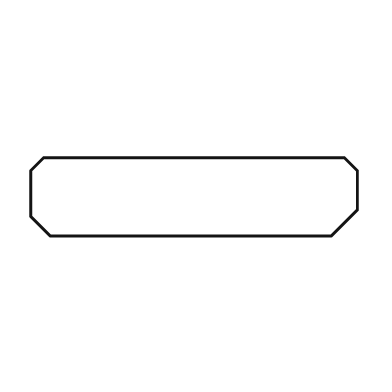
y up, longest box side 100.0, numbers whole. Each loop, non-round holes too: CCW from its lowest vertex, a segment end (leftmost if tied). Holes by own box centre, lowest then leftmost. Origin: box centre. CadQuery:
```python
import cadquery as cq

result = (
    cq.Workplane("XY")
    .moveTo(-44.0, -12.0)
    .lineTo(42.0, -12.0)
    .lineTo(50.0, -4.0)
    .lineTo(50.0, 8.0)
    .lineTo(46.0, 12.0)
    .lineTo(-46.0, 12.0)
    .lineTo(-50.0, 8.0)
    .lineTo(-50.0, -6.0)
    .close()
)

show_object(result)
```